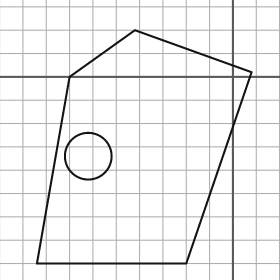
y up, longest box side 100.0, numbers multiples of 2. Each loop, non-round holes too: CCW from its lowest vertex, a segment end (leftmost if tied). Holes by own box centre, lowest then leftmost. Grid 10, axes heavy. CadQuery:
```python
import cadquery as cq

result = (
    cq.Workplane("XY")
    .moveTo(-84.0, -80.0)
    .lineTo(-20.0, -80.0)
    .lineTo(8.0, 2.0)
    .lineTo(-42.0, 20.0)
    .lineTo(-70.0, 0.0)
    .close()
    .moveTo(-62.0, -34.0)
    .circle(10.0)
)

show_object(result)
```